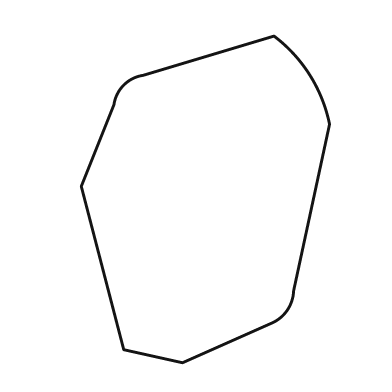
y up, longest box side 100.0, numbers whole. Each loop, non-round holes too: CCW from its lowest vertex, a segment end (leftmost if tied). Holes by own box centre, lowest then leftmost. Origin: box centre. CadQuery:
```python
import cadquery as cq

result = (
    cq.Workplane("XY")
    .moveTo(-7.0, -50.0)
    .lineTo(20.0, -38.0)
    .threePointArc((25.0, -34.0), (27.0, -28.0))
    .lineTo(38.0, 23.0)
    .threePointArc((32.0, 38.0), (21.0, 50.0))
    .lineTo(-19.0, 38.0)
    .threePointArc((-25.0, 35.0), (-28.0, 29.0))
    .lineTo(-38.0, 4.0)
    .lineTo(-25.0, -46.0)
    .close()
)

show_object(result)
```